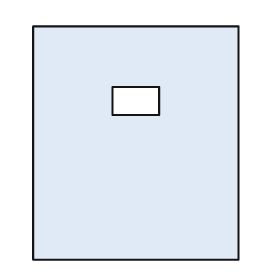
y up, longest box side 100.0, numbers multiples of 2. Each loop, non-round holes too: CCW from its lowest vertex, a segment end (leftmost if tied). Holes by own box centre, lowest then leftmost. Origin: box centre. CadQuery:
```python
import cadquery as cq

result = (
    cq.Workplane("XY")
    .moveTo(-44.0, -50.0)
    .lineTo(44.0, -50.0)
    .lineTo(44.0, 50.0)
    .lineTo(-44.0, 50.0)
    .close()
    .moveTo(-10.0, 12.0)
    .lineTo(10.0, 12.0)
    .lineTo(10.0, 24.0)
    .lineTo(-10.0, 24.0)
    .close()
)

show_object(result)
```